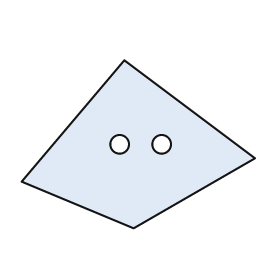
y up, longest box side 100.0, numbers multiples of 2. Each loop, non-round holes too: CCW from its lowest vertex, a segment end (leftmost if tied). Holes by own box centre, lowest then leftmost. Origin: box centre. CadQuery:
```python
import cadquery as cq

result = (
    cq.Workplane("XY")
    .moveTo(-2.0, -36.0)
    .lineTo(50.0, -6.0)
    .lineTo(-6.0, 36.0)
    .lineTo(-50.0, -16.0)
    .close()
    .moveTo(-8.0, 0.0)
    .circle(4.0)
    .moveTo(10.0, 0.0)
    .circle(4.0)
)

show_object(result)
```